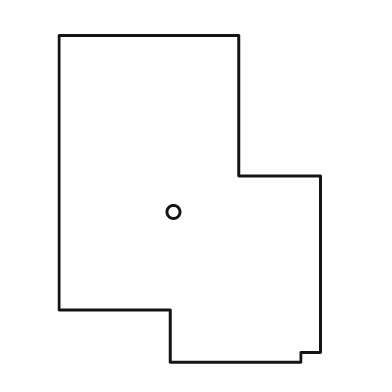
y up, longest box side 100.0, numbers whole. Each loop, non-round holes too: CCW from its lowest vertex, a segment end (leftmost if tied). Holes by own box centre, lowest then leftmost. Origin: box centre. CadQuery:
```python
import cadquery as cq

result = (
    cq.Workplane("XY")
    .moveTo(-6.0, -50.0)
    .lineTo(34.0, -50.0)
    .lineTo(34.0, -47.0)
    .lineTo(40.0, -47.0)
    .lineTo(40.0, 7.0)
    .lineTo(15.0, 7.0)
    .lineTo(15.0, 50.0)
    .lineTo(-40.0, 50.0)
    .lineTo(-40.0, -34.0)
    .lineTo(-6.0, -34.0)
    .close()
    .moveTo(-5.0, -4.0)
    .circle(2.0)
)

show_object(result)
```